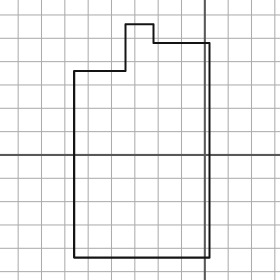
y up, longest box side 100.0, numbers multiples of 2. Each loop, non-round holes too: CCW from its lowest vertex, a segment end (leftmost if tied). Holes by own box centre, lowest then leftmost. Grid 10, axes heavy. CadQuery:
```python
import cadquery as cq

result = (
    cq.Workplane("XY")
    .moveTo(-56.0, -44.0)
    .lineTo(2.0, -44.0)
    .lineTo(2.0, 48.0)
    .lineTo(-22.0, 48.0)
    .lineTo(-22.0, 56.0)
    .lineTo(-34.0, 56.0)
    .lineTo(-34.0, 36.0)
    .lineTo(-56.0, 36.0)
    .close()
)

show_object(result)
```